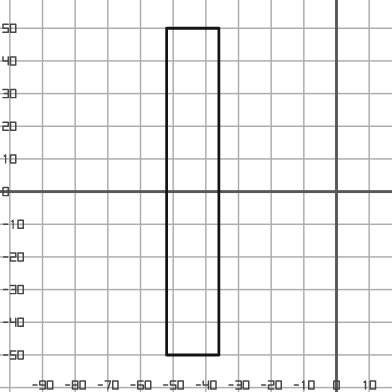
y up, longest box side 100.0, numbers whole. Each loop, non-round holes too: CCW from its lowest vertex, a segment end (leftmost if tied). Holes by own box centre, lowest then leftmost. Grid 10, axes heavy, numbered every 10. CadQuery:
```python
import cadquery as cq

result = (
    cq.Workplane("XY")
    .moveTo(-52.0, -50.0)
    .lineTo(-36.0, -50.0)
    .lineTo(-36.0, 50.0)
    .lineTo(-52.0, 50.0)
    .close()
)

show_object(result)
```